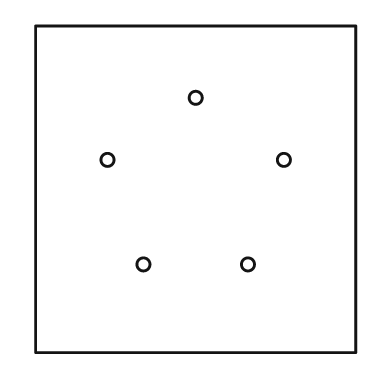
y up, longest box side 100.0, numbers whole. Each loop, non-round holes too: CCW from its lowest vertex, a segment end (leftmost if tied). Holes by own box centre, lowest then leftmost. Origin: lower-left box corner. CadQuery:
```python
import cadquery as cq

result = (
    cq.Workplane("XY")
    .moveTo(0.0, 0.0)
    .lineTo(98.0, 0.0)
    .lineTo(98.0, 100.0)
    .lineTo(0.0, 100.0)
    .close()
    .moveTo(33.0, 27.0)
    .circle(2.0)
    .moveTo(65.0, 27.0)
    .circle(2.0)
    .moveTo(22.0, 59.0)
    .circle(2.0)
    .moveTo(76.0, 59.0)
    .circle(2.0)
    .moveTo(49.0, 78.0)
    .circle(2.0)
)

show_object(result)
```